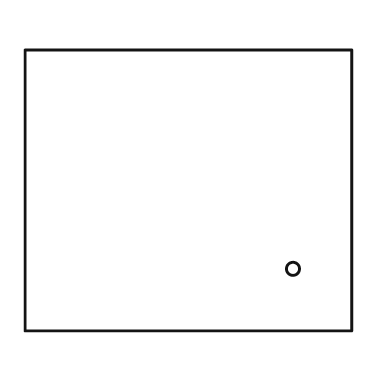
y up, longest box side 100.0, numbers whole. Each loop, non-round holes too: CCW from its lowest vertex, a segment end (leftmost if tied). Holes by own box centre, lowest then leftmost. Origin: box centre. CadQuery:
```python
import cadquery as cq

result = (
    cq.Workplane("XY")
    .moveTo(-50.0, -43.0)
    .lineTo(50.0, -43.0)
    .lineTo(50.0, 43.0)
    .lineTo(-50.0, 43.0)
    .close()
    .moveTo(32.0, -24.0)
    .circle(2.0)
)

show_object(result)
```